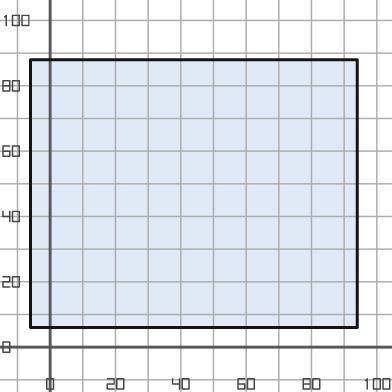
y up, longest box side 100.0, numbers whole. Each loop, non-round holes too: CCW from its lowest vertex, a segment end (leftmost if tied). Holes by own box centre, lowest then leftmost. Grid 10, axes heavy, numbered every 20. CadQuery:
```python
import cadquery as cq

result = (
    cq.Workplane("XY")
    .moveTo(-6.0, 6.0)
    .lineTo(94.0, 6.0)
    .lineTo(94.0, 88.0)
    .lineTo(-6.0, 88.0)
    .close()
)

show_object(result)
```